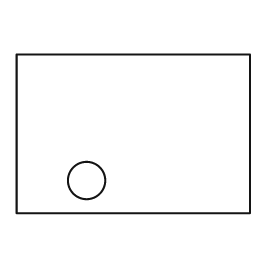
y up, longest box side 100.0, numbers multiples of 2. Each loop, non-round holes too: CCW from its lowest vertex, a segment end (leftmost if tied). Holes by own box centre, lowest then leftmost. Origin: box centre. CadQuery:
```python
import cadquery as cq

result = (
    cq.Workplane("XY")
    .moveTo(-50.0, -34.0)
    .lineTo(50.0, -34.0)
    .lineTo(50.0, 34.0)
    .lineTo(-50.0, 34.0)
    .close()
    .moveTo(-20.0, -20.0)
    .circle(8.0)
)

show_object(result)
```